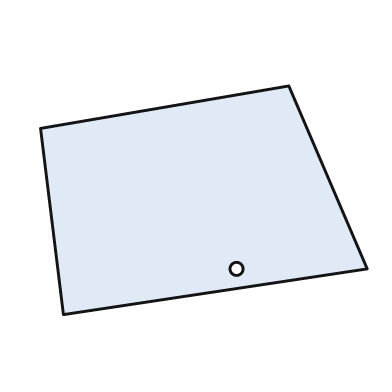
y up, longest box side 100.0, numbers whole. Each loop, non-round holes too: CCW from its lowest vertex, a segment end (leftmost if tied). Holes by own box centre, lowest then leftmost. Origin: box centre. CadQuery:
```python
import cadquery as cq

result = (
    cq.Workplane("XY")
    .moveTo(-43.0, -35.0)
    .lineTo(50.0, -21.0)
    .lineTo(26.0, 35.0)
    .lineTo(-50.0, 22.0)
    .close()
    .moveTo(10.0, -21.0)
    .circle(2.0)
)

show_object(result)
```